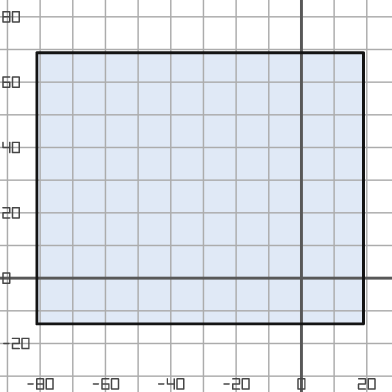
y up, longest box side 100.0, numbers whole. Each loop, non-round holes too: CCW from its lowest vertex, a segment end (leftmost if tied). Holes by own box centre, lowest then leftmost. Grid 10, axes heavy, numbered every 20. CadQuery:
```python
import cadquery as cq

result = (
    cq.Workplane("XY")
    .moveTo(-81.0, -14.0)
    .lineTo(19.0, -14.0)
    .lineTo(19.0, 69.0)
    .lineTo(-81.0, 69.0)
    .close()
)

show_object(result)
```